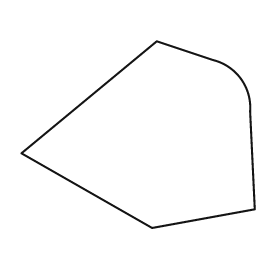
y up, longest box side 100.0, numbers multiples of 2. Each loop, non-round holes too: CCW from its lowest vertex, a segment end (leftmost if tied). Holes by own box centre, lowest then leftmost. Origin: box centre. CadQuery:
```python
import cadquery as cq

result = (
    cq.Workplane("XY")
    .moveTo(6.0, -40.0)
    .lineTo(50.0, -32.0)
    .lineTo(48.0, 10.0)
    .threePointArc((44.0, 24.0), (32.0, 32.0))
    .lineTo(8.0, 40.0)
    .lineTo(-50.0, -8.0)
    .close()
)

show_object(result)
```